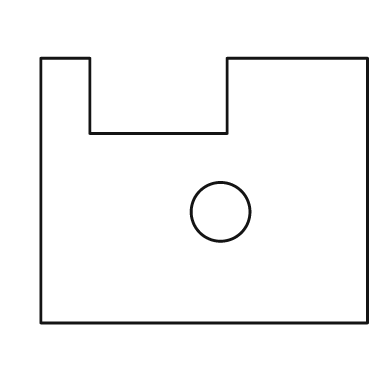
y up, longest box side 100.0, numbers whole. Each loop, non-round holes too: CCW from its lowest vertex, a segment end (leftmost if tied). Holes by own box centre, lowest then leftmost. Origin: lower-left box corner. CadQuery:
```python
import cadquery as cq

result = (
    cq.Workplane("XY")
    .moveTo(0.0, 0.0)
    .lineTo(100.0, 0.0)
    .lineTo(100.0, 81.0)
    .lineTo(57.0, 81.0)
    .lineTo(57.0, 58.0)
    .lineTo(15.0, 58.0)
    .lineTo(15.0, 81.0)
    .lineTo(0.0, 81.0)
    .close()
    .moveTo(55.0, 34.0)
    .circle(9.0)
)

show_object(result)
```